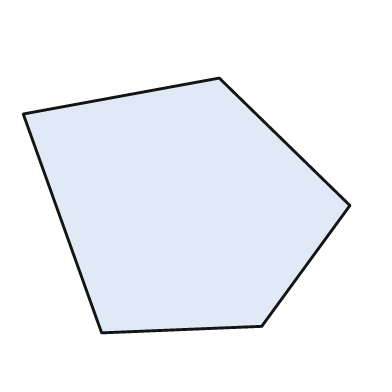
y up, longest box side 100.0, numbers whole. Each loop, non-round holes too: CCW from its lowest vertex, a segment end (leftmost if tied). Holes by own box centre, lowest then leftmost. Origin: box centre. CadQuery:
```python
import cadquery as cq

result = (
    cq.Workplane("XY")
    .moveTo(-26.0, -39.0)
    .lineTo(23.0, -37.0)
    .lineTo(50.0, 0.0)
    .lineTo(10.0, 39.0)
    .lineTo(-50.0, 28.0)
    .close()
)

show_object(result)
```